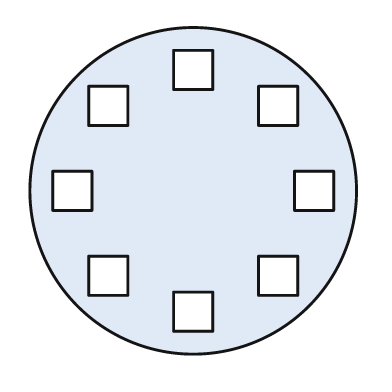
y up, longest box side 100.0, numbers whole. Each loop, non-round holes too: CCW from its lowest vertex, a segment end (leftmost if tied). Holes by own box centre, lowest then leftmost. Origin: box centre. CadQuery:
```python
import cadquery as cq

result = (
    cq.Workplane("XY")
    .moveTo(0.0, 0.0)
    .circle(50.0)
    .moveTo(-6.0, -43.0)
    .lineTo(6.0, -43.0)
    .lineTo(6.0, -31.0)
    .lineTo(-6.0, -31.0)
    .close()
    .moveTo(-32.0, -32.0)
    .lineTo(-20.0, -32.0)
    .lineTo(-20.0, -20.0)
    .lineTo(-32.0, -20.0)
    .close()
    .moveTo(20.0, -32.0)
    .lineTo(32.0, -32.0)
    .lineTo(32.0, -20.0)
    .lineTo(20.0, -20.0)
    .close()
    .moveTo(-43.0, -6.0)
    .lineTo(-31.0, -6.0)
    .lineTo(-31.0, 6.0)
    .lineTo(-43.0, 6.0)
    .close()
    .moveTo(31.0, -6.0)
    .lineTo(43.0, -6.0)
    .lineTo(43.0, 6.0)
    .lineTo(31.0, 6.0)
    .close()
    .moveTo(-32.0, 20.0)
    .lineTo(-20.0, 20.0)
    .lineTo(-20.0, 32.0)
    .lineTo(-32.0, 32.0)
    .close()
    .moveTo(20.0, 20.0)
    .lineTo(32.0, 20.0)
    .lineTo(32.0, 32.0)
    .lineTo(20.0, 32.0)
    .close()
    .moveTo(-6.0, 31.0)
    .lineTo(6.0, 31.0)
    .lineTo(6.0, 43.0)
    .lineTo(-6.0, 43.0)
    .close()
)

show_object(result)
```